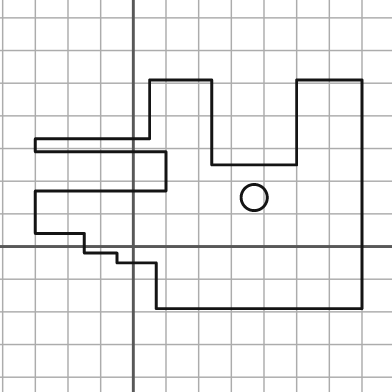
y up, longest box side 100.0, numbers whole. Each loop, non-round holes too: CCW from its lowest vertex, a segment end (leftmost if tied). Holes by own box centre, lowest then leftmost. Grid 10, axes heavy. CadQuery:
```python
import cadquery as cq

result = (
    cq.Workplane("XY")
    .moveTo(7.0, -19.0)
    .lineTo(70.0, -19.0)
    .lineTo(70.0, 51.0)
    .lineTo(50.0, 51.0)
    .lineTo(50.0, 25.0)
    .lineTo(24.0, 25.0)
    .lineTo(24.0, 51.0)
    .lineTo(5.0, 51.0)
    .lineTo(5.0, 33.0)
    .lineTo(-30.0, 33.0)
    .lineTo(-30.0, 29.0)
    .lineTo(10.0, 29.0)
    .lineTo(10.0, 17.0)
    .lineTo(-30.0, 17.0)
    .lineTo(-30.0, 4.0)
    .lineTo(-15.0, 4.0)
    .lineTo(-15.0, -2.0)
    .lineTo(-5.0, -2.0)
    .lineTo(-5.0, -5.0)
    .lineTo(7.0, -5.0)
    .close()
    .moveTo(37.0, 15.0)
    .circle(4.0)
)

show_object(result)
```